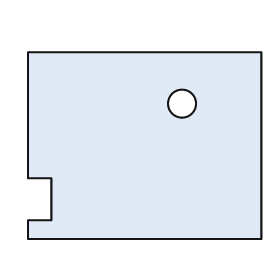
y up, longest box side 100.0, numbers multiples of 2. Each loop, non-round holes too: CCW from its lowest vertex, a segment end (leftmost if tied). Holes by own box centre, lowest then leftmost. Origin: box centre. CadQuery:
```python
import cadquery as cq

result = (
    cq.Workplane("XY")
    .moveTo(-50.0, -40.0)
    .lineTo(50.0, -40.0)
    .lineTo(50.0, 40.0)
    .lineTo(-50.0, 40.0)
    .lineTo(-50.0, -14.0)
    .lineTo(-40.0, -14.0)
    .lineTo(-40.0, -32.0)
    .lineTo(-50.0, -32.0)
    .close()
    .moveTo(16.0, 18.0)
    .circle(6.0)
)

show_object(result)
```